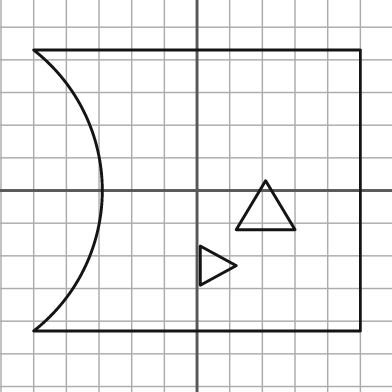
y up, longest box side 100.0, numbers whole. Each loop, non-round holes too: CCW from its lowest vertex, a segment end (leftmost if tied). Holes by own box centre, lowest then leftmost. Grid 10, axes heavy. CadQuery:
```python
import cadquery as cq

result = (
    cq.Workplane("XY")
    .moveTo(-50.0, -43.0)
    .lineTo(50.0, -43.0)
    .lineTo(50.0, 43.0)
    .lineTo(-50.0, 43.0)
    .threePointArc((-29.0, 0.0), (-50.0, -43.0))
    .close()
    .moveTo(1.0, -29.0)
    .lineTo(12.0, -23.0)
    .lineTo(1.0, -17.0)
    .close()
    .moveTo(12.0, -12.0)
    .lineTo(30.0, -12.0)
    .lineTo(21.0, 3.0)
    .close()
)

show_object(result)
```